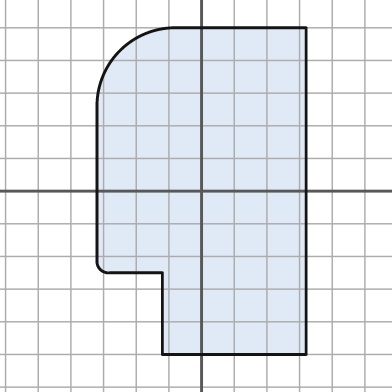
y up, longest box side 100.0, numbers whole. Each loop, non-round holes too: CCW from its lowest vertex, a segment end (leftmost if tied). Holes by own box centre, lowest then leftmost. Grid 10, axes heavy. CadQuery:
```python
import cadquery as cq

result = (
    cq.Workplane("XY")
    .moveTo(-12.0, -50.0)
    .lineTo(32.0, -50.0)
    .lineTo(32.0, 50.0)
    .lineTo(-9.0, 50.0)
    .threePointArc((-25.0, 43.0), (-32.0, 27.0))
    .lineTo(-32.0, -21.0)
    .threePointArc((-31.0, -24.0), (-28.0, -25.0))
    .lineTo(-12.0, -25.0)
    .close()
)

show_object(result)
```